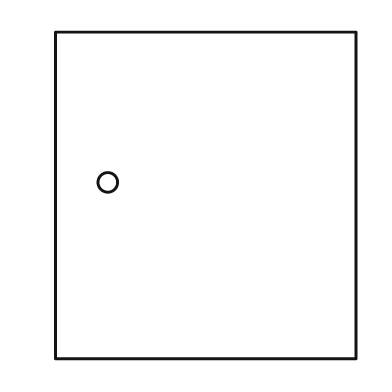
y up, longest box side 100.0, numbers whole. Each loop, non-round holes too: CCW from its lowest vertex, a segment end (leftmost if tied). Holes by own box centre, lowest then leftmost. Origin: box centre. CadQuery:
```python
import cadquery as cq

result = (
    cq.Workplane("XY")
    .moveTo(-46.0, -50.0)
    .lineTo(46.0, -50.0)
    .lineTo(46.0, 50.0)
    .lineTo(-46.0, 50.0)
    .close()
    .moveTo(-30.0, 4.0)
    .circle(3.0)
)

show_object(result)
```